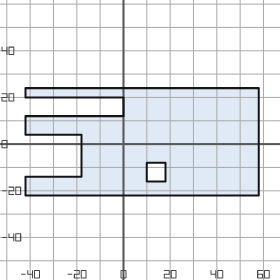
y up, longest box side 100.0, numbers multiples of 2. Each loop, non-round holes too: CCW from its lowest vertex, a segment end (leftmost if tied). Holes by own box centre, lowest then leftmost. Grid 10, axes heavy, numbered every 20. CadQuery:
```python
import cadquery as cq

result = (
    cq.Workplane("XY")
    .moveTo(-42.0, -22.0)
    .lineTo(58.0, -22.0)
    .lineTo(58.0, 24.0)
    .lineTo(-42.0, 24.0)
    .lineTo(-42.0, 20.0)
    .lineTo(0.0, 20.0)
    .lineTo(0.0, 12.0)
    .lineTo(-42.0, 12.0)
    .lineTo(-42.0, 4.0)
    .lineTo(-18.0, 4.0)
    .lineTo(-18.0, -14.0)
    .lineTo(-42.0, -14.0)
    .close()
    .moveTo(10.0, -16.0)
    .lineTo(18.0, -16.0)
    .lineTo(18.0, -8.0)
    .lineTo(10.0, -8.0)
    .close()
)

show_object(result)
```